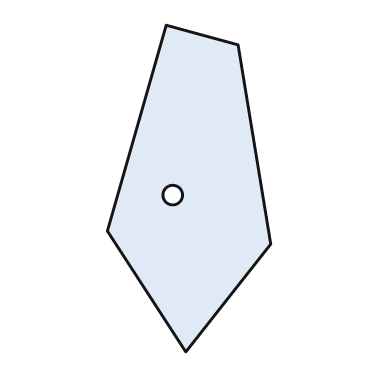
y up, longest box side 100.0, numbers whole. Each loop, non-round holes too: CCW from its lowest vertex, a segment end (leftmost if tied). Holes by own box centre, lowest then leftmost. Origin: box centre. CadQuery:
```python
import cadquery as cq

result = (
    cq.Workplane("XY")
    .moveTo(-1.0, -50.0)
    .lineTo(25.0, -17.0)
    .lineTo(15.0, 44.0)
    .lineTo(-7.0, 50.0)
    .lineTo(-25.0, -13.0)
    .close()
    .moveTo(-5.0, -2.0)
    .circle(3.0)
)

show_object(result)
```